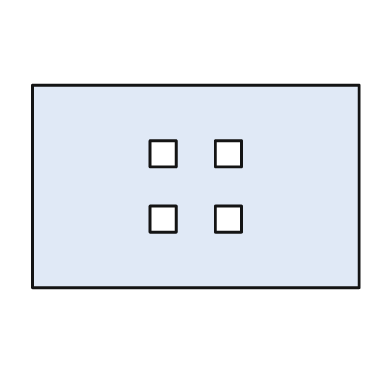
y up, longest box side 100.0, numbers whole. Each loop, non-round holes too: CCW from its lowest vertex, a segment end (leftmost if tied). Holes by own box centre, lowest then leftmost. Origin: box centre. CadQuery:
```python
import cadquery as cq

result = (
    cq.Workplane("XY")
    .moveTo(-50.0, -31.0)
    .lineTo(50.0, -31.0)
    .lineTo(50.0, 31.0)
    .lineTo(-50.0, 31.0)
    .close()
    .moveTo(-14.0, -14.0)
    .lineTo(-6.0, -14.0)
    .lineTo(-6.0, -6.0)
    .lineTo(-14.0, -6.0)
    .close()
    .moveTo(6.0, -14.0)
    .lineTo(14.0, -14.0)
    .lineTo(14.0, -6.0)
    .lineTo(6.0, -6.0)
    .close()
    .moveTo(-14.0, 6.0)
    .lineTo(-6.0, 6.0)
    .lineTo(-6.0, 14.0)
    .lineTo(-14.0, 14.0)
    .close()
    .moveTo(6.0, 6.0)
    .lineTo(14.0, 6.0)
    .lineTo(14.0, 14.0)
    .lineTo(6.0, 14.0)
    .close()
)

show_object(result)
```